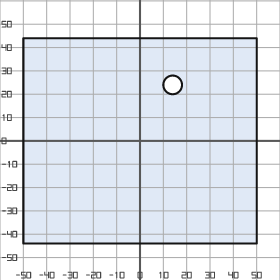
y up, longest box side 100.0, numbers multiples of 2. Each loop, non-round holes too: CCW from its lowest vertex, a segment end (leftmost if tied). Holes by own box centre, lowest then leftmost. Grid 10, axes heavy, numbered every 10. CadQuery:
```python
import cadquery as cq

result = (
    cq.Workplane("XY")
    .moveTo(-50.0, -44.0)
    .lineTo(50.0, -44.0)
    .lineTo(50.0, 44.0)
    .lineTo(-50.0, 44.0)
    .close()
    .moveTo(14.0, 24.0)
    .circle(4.0)
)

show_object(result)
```